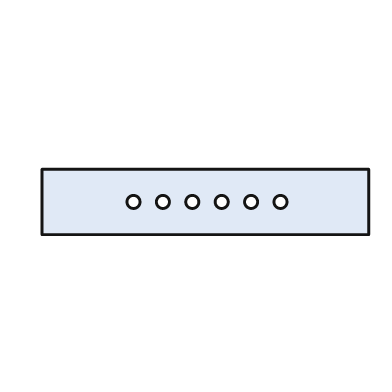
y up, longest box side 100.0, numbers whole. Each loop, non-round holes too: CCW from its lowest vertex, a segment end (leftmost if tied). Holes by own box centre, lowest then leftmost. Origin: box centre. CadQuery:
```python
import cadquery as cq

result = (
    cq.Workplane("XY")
    .moveTo(-50.0, -10.0)
    .lineTo(50.0, -10.0)
    .lineTo(50.0, 10.0)
    .lineTo(-50.0, 10.0)
    .close()
    .moveTo(-22.0, 0.0)
    .circle(2.0)
    .moveTo(-13.0, 0.0)
    .circle(2.0)
    .moveTo(-4.0, 0.0)
    .circle(2.0)
    .moveTo(5.0, 0.0)
    .circle(2.0)
    .moveTo(14.0, 0.0)
    .circle(2.0)
    .moveTo(23.0, 0.0)
    .circle(2.0)
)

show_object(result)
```